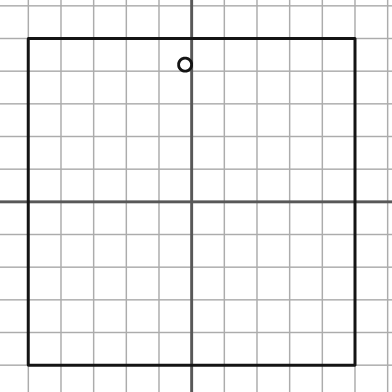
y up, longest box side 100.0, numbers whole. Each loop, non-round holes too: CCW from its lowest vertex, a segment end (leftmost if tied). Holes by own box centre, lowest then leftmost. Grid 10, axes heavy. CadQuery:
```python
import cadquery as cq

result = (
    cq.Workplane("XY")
    .moveTo(-50.0, -50.0)
    .lineTo(50.0, -50.0)
    .lineTo(50.0, 50.0)
    .lineTo(-50.0, 50.0)
    .close()
    .moveTo(-2.0, 42.0)
    .circle(2.0)
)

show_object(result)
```